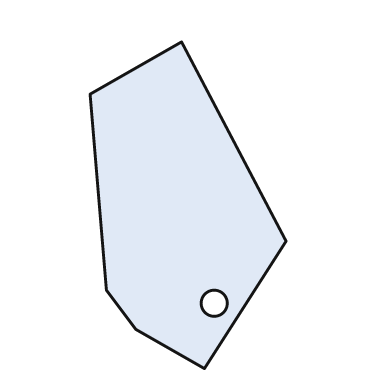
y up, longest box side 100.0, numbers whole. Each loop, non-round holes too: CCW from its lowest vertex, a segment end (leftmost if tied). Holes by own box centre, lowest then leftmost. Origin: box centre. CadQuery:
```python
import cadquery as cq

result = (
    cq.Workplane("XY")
    .moveTo(5.0, -50.0)
    .lineTo(30.0, -11.0)
    .lineTo(-2.0, 50.0)
    .lineTo(-30.0, 34.0)
    .lineTo(-25.0, -26.0)
    .lineTo(-16.0, -38.0)
    .close()
    .moveTo(8.0, -30.0)
    .circle(4.0)
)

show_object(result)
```